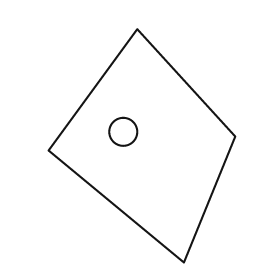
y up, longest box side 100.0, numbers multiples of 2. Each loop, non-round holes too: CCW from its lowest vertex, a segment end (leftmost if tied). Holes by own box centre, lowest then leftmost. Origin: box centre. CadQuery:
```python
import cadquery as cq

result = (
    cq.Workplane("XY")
    .moveTo(18.0, -50.0)
    .lineTo(40.0, 4.0)
    .lineTo(-2.0, 50.0)
    .lineTo(-40.0, -2.0)
    .close()
    .moveTo(-8.0, 6.0)
    .circle(6.0)
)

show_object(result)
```